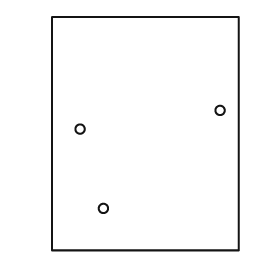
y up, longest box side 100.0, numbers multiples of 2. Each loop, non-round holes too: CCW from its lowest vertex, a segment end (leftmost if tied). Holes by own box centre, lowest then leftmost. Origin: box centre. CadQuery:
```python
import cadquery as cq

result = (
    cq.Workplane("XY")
    .moveTo(-40.0, -50.0)
    .lineTo(40.0, -50.0)
    .lineTo(40.0, 50.0)
    .lineTo(-40.0, 50.0)
    .close()
    .moveTo(-18.0, -32.0)
    .circle(2.0)
    .moveTo(-28.0, 2.0)
    .circle(2.0)
    .moveTo(32.0, 10.0)
    .circle(2.0)
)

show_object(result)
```